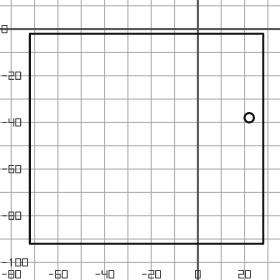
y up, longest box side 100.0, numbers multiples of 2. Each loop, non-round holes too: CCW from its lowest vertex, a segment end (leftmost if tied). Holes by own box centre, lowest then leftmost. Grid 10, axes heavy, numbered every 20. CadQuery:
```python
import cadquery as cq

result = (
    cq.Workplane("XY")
    .moveTo(-72.0, -92.0)
    .lineTo(28.0, -92.0)
    .lineTo(28.0, -2.0)
    .lineTo(-72.0, -2.0)
    .close()
    .moveTo(22.0, -38.0)
    .circle(2.0)
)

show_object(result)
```